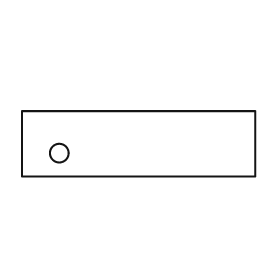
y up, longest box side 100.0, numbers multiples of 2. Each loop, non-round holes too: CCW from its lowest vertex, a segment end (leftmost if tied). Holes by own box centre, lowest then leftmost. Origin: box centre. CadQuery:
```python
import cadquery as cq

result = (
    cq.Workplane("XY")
    .moveTo(-50.0, -14.0)
    .lineTo(50.0, -14.0)
    .lineTo(50.0, 14.0)
    .lineTo(-50.0, 14.0)
    .close()
    .moveTo(-34.0, -4.0)
    .circle(4.0)
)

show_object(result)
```